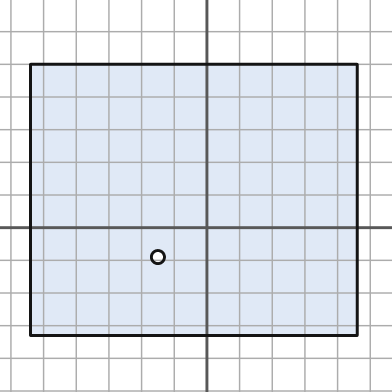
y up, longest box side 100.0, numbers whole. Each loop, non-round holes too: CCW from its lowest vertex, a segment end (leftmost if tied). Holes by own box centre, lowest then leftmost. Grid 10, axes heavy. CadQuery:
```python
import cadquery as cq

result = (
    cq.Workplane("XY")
    .moveTo(-54.0, -33.0)
    .lineTo(46.0, -33.0)
    .lineTo(46.0, 50.0)
    .lineTo(-54.0, 50.0)
    .close()
    .moveTo(-15.0, -9.0)
    .circle(2.0)
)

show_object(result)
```